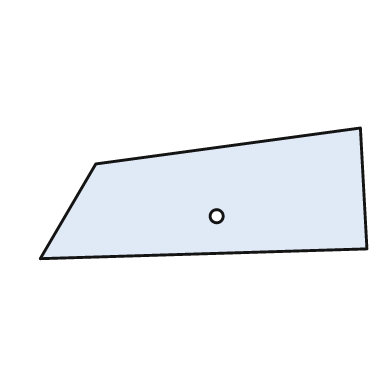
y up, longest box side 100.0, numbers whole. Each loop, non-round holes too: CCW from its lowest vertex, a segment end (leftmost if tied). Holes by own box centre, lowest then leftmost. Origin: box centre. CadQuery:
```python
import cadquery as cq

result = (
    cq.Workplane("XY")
    .moveTo(-50.0, -20.0)
    .lineTo(50.0, -17.0)
    .lineTo(48.0, 20.0)
    .lineTo(-33.0, 9.0)
    .close()
    .moveTo(4.0, -7.0)
    .circle(2.0)
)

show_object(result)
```